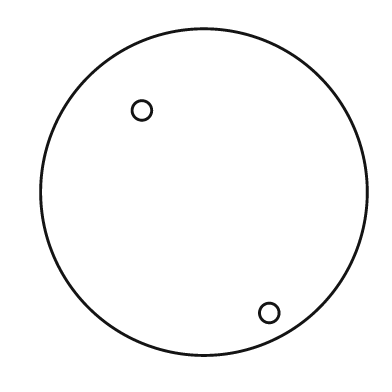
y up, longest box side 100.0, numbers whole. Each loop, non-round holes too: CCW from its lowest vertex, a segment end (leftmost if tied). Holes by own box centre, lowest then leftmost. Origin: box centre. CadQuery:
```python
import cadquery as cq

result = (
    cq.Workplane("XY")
    .moveTo(0.0, 0.0)
    .circle(50.0)
    .moveTo(20.0, -37.0)
    .circle(3.0)
    .moveTo(-19.0, 25.0)
    .circle(3.0)
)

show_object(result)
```